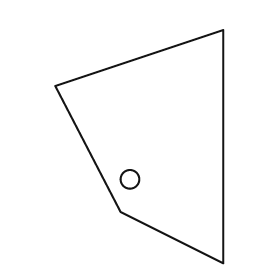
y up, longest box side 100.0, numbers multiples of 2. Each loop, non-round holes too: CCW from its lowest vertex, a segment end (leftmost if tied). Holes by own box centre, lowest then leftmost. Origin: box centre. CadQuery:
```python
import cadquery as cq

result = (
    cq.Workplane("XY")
    .moveTo(36.0, -50.0)
    .lineTo(36.0, 50.0)
    .lineTo(-36.0, 26.0)
    .lineTo(-8.0, -28.0)
    .close()
    .moveTo(-4.0, -14.0)
    .circle(4.0)
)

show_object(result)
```